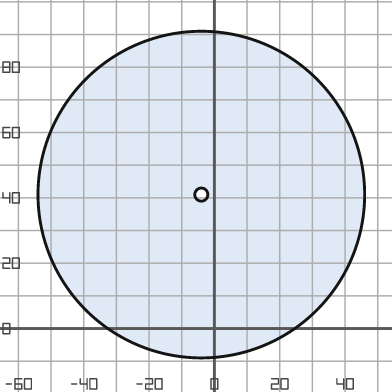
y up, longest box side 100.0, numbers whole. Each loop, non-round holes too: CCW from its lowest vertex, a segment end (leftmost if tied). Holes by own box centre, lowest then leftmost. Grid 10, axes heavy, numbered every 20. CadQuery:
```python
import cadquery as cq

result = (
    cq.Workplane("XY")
    .moveTo(-4.0, 41.0)
    .circle(50.0)
    .moveTo(-4.0, 41.0)
    .circle(2.0)
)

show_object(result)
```